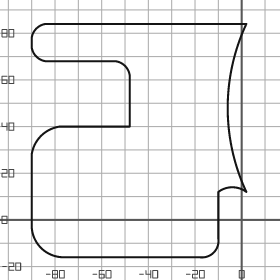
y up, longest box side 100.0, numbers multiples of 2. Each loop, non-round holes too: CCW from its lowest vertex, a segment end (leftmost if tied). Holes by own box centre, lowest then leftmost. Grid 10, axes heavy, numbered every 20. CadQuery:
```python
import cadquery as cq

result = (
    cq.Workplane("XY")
    .moveTo(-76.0, -16.0)
    .lineTo(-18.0, -16.0)
    .threePointArc((-12.0, -14.0), (-10.0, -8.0))
    .lineTo(-10.0, 12.0)
    .threePointArc((-4.0, 14.0), (2.0, 12.0))
    .threePointArc((-6.0, 48.0), (2.0, 84.0))
    .lineTo(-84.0, 84.0)
    .threePointArc((-88.0, 82.0), (-90.0, 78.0))
    .lineTo(-90.0, 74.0)
    .threePointArc((-88.0, 70.0), (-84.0, 68.0))
    .lineTo(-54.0, 68.0)
    .threePointArc((-50.0, 66.0), (-48.0, 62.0))
    .lineTo(-48.0, 40.0)
    .lineTo(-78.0, 40.0)
    .threePointArc((-86.0, 36.0), (-90.0, 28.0))
    .lineTo(-90.0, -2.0)
    .threePointArc((-86.0, -12.0), (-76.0, -16.0))
    .close()
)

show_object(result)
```